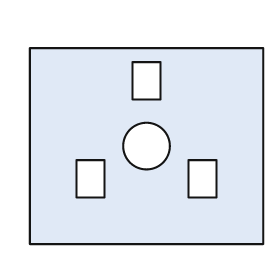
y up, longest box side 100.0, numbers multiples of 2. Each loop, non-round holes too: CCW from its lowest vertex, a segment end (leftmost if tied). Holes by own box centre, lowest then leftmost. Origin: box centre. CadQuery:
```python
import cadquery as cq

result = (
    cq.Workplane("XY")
    .moveTo(-50.0, -42.0)
    .lineTo(50.0, -42.0)
    .lineTo(50.0, 42.0)
    .lineTo(-50.0, 42.0)
    .close()
    .moveTo(-30.0, -22.0)
    .lineTo(-18.0, -22.0)
    .lineTo(-18.0, -6.0)
    .lineTo(-30.0, -6.0)
    .close()
    .moveTo(18.0, -22.0)
    .lineTo(30.0, -22.0)
    .lineTo(30.0, -6.0)
    .lineTo(18.0, -6.0)
    .close()
    .moveTo(0.0, 0.0)
    .circle(10.0)
    .moveTo(-6.0, 20.0)
    .lineTo(6.0, 20.0)
    .lineTo(6.0, 36.0)
    .lineTo(-6.0, 36.0)
    .close()
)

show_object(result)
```